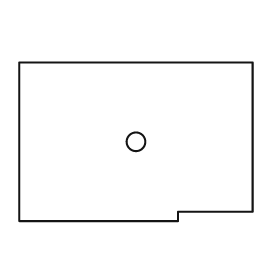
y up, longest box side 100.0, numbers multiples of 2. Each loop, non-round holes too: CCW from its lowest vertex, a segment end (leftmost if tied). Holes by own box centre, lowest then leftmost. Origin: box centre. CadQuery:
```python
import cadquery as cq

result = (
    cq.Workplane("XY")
    .moveTo(-50.0, -34.0)
    .lineTo(18.0, -34.0)
    .lineTo(18.0, -30.0)
    .lineTo(50.0, -30.0)
    .lineTo(50.0, 34.0)
    .lineTo(-50.0, 34.0)
    .close()
    .moveTo(0.0, 0.0)
    .circle(4.0)
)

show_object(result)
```